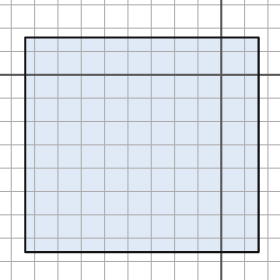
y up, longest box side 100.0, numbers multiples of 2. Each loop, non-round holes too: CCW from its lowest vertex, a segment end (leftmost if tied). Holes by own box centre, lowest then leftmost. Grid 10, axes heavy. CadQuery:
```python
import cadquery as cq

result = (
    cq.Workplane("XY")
    .moveTo(-84.0, -76.0)
    .lineTo(16.0, -76.0)
    .lineTo(16.0, 16.0)
    .lineTo(-84.0, 16.0)
    .close()
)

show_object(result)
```